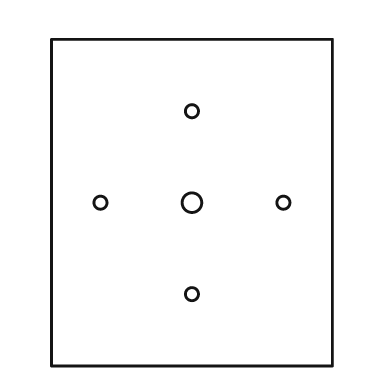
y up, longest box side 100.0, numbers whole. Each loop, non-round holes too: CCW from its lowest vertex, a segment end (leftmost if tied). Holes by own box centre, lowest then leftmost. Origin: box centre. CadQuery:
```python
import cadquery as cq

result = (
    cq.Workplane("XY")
    .moveTo(-43.0, -50.0)
    .lineTo(43.0, -50.0)
    .lineTo(43.0, 50.0)
    .lineTo(-43.0, 50.0)
    .close()
    .moveTo(0.0, -28.0)
    .circle(2.0)
    .moveTo(-28.0, 0.0)
    .circle(2.0)
    .moveTo(0.0, 0.0)
    .circle(3.0)
    .moveTo(28.0, 0.0)
    .circle(2.0)
    .moveTo(0.0, 28.0)
    .circle(2.0)
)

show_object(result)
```